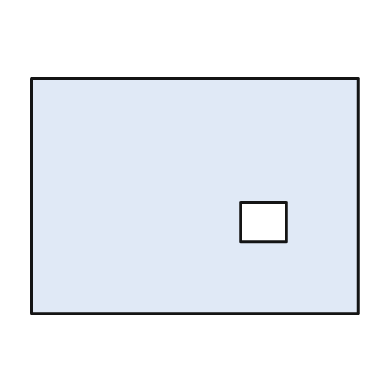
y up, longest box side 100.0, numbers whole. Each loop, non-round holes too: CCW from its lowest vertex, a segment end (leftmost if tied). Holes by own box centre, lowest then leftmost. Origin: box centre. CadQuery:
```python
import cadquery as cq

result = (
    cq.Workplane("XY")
    .moveTo(-50.0, -36.0)
    .lineTo(50.0, -36.0)
    .lineTo(50.0, 36.0)
    .lineTo(-50.0, 36.0)
    .close()
    .moveTo(14.0, -14.0)
    .lineTo(28.0, -14.0)
    .lineTo(28.0, -2.0)
    .lineTo(14.0, -2.0)
    .close()
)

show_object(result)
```